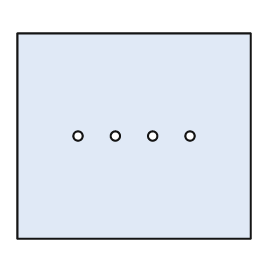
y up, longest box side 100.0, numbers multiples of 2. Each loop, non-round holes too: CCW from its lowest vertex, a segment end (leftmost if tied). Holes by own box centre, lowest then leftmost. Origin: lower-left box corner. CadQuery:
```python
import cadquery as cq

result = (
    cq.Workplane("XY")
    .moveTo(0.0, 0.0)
    .lineTo(100.0, 0.0)
    .lineTo(100.0, 88.0)
    .lineTo(0.0, 88.0)
    .close()
    .moveTo(26.0, 44.0)
    .circle(2.0)
    .moveTo(42.0, 44.0)
    .circle(2.0)
    .moveTo(58.0, 44.0)
    .circle(2.0)
    .moveTo(74.0, 44.0)
    .circle(2.0)
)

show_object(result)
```